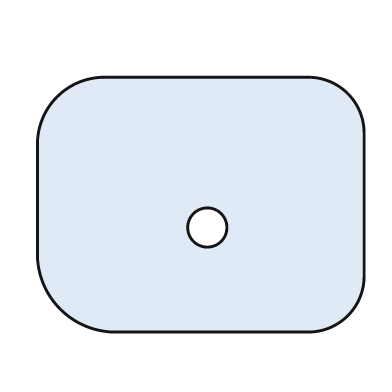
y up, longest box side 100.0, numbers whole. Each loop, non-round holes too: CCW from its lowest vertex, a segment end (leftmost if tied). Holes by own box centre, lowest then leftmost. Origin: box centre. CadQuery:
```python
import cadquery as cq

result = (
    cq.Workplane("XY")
    .moveTo(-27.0, -39.0)
    .lineTo(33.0, -39.0)
    .threePointArc((45.0, -34.0), (50.0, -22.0))
    .lineTo(50.0, 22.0)
    .threePointArc((45.0, 34.0), (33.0, 39.0))
    .lineTo(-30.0, 39.0)
    .threePointArc((-44.0, 33.0), (-50.0, 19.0))
    .lineTo(-50.0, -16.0)
    .threePointArc((-43.0, -32.0), (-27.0, -39.0))
    .close()
    .moveTo(2.0, -7.0)
    .circle(6.0)
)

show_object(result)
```